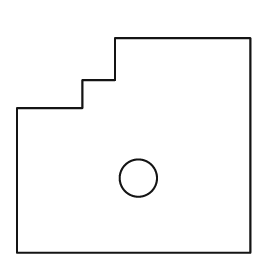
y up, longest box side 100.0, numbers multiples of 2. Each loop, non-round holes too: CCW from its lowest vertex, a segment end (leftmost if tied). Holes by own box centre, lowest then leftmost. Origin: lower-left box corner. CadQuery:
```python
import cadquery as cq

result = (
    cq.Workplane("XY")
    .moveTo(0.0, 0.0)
    .lineTo(100.0, 0.0)
    .lineTo(100.0, 92.0)
    .lineTo(42.0, 92.0)
    .lineTo(42.0, 74.0)
    .lineTo(28.0, 74.0)
    .lineTo(28.0, 62.0)
    .lineTo(0.0, 62.0)
    .close()
    .moveTo(52.0, 32.0)
    .circle(8.0)
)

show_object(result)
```